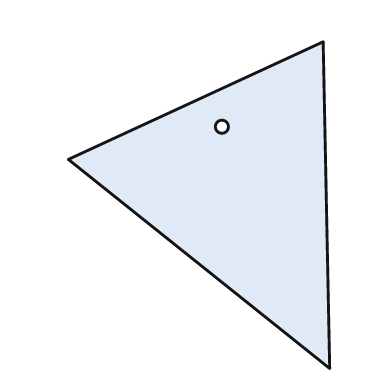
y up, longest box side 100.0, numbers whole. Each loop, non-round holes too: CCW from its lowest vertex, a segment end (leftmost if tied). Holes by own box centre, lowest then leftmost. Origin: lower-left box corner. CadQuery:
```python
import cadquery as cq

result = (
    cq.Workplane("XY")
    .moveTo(80.0, 0.0)
    .lineTo(78.0, 100.0)
    .lineTo(0.0, 64.0)
    .close()
    .moveTo(47.0, 74.0)
    .circle(2.0)
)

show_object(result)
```